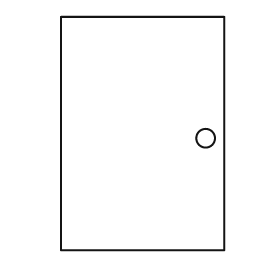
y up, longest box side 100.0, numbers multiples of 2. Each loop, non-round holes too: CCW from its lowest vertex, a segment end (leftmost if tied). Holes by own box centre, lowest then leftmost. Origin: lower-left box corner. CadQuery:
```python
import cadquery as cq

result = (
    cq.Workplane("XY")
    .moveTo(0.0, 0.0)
    .lineTo(70.0, 0.0)
    .lineTo(70.0, 100.0)
    .lineTo(0.0, 100.0)
    .close()
    .moveTo(62.0, 48.0)
    .circle(4.0)
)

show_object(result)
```